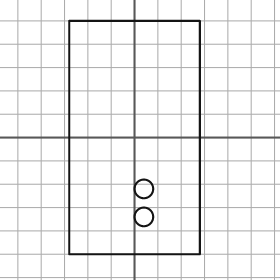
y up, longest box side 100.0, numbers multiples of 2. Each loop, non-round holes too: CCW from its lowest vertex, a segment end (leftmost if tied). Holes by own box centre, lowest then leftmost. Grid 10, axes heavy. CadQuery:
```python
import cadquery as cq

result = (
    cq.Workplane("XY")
    .moveTo(-28.0, -50.0)
    .lineTo(28.0, -50.0)
    .lineTo(28.0, 50.0)
    .lineTo(-28.0, 50.0)
    .close()
    .moveTo(4.0, -34.0)
    .circle(4.0)
    .moveTo(4.0, -22.0)
    .circle(4.0)
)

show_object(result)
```